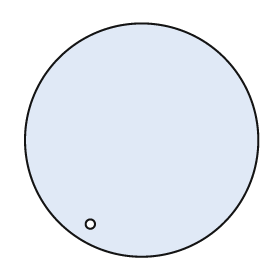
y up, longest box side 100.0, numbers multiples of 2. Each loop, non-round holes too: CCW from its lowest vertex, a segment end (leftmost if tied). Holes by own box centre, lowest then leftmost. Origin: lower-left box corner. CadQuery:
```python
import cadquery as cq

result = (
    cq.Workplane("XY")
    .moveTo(50.0, 50.0)
    .circle(50.0)
    .moveTo(28.0, 14.0)
    .circle(2.0)
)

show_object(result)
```